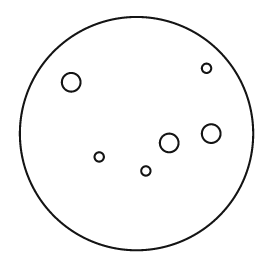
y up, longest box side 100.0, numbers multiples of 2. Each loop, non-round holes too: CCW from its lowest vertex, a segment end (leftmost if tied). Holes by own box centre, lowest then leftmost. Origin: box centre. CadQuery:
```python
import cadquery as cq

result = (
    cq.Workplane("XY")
    .moveTo(0.0, 0.0)
    .circle(50.0)
    .moveTo(4.0, -16.0)
    .circle(2.0)
    .moveTo(-16.0, -10.0)
    .circle(2.0)
    .moveTo(14.0, -4.0)
    .circle(4.0)
    .moveTo(32.0, 0.0)
    .circle(4.0)
    .moveTo(-28.0, 22.0)
    .circle(4.0)
    .moveTo(30.0, 28.0)
    .circle(2.0)
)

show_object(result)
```